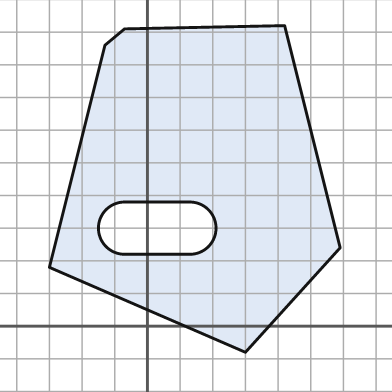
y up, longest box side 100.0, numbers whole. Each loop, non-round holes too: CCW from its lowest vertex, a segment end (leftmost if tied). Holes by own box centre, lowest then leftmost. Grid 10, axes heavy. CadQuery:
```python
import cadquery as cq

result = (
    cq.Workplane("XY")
    .moveTo(30.0, -8.0)
    .lineTo(59.0, 24.0)
    .lineTo(42.0, 92.0)
    .lineTo(-7.0, 91.0)
    .lineTo(-13.0, 86.0)
    .lineTo(-30.0, 18.0)
    .close()
    .moveTo(-7.0, 22.0)
    .lineTo(13.0, 22.0)
    .threePointArc((21.0, 30.0), (13.0, 38.0))
    .lineTo(-7.0, 38.0)
    .threePointArc((-15.0, 30.0), (-7.0, 22.0))
    .close()
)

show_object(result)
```